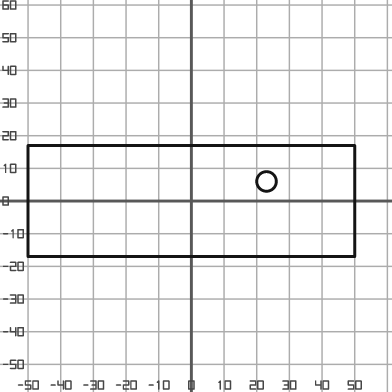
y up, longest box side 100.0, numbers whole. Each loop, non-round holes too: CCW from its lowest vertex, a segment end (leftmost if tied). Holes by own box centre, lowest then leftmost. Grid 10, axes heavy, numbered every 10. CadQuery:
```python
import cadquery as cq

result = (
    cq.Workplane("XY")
    .moveTo(-50.0, -17.0)
    .lineTo(50.0, -17.0)
    .lineTo(50.0, 17.0)
    .lineTo(-50.0, 17.0)
    .close()
    .moveTo(23.0, 6.0)
    .circle(3.0)
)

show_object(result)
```